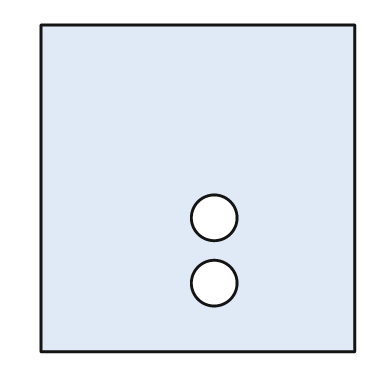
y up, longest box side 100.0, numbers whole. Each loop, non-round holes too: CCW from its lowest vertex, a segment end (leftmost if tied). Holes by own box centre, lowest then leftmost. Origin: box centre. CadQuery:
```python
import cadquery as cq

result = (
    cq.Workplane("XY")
    .moveTo(-48.0, -50.0)
    .lineTo(48.0, -50.0)
    .lineTo(48.0, 50.0)
    .lineTo(-48.0, 50.0)
    .close()
    .moveTo(5.0, -29.0)
    .circle(7.0)
    .moveTo(5.0, -9.0)
    .circle(7.0)
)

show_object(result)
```